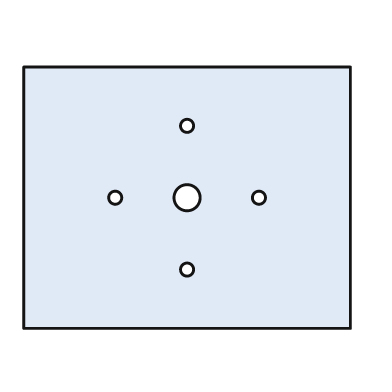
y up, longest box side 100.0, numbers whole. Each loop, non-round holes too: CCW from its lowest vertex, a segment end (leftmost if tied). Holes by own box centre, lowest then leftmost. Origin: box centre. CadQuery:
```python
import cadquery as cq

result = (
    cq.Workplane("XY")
    .moveTo(-50.0, -40.0)
    .lineTo(50.0, -40.0)
    .lineTo(50.0, 40.0)
    .lineTo(-50.0, 40.0)
    .close()
    .moveTo(0.0, -22.0)
    .circle(2.0)
    .moveTo(-22.0, 0.0)
    .circle(2.0)
    .moveTo(0.0, 0.0)
    .circle(4.0)
    .moveTo(22.0, 0.0)
    .circle(2.0)
    .moveTo(0.0, 22.0)
    .circle(2.0)
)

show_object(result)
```